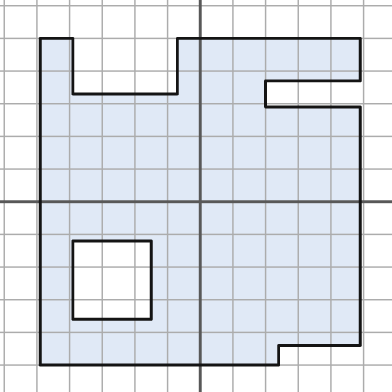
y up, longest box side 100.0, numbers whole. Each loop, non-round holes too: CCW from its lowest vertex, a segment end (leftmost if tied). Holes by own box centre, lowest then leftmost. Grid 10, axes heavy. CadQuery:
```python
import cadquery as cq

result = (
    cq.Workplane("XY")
    .moveTo(-49.0, -50.0)
    .lineTo(24.0, -50.0)
    .lineTo(24.0, -44.0)
    .lineTo(49.0, -44.0)
    .lineTo(49.0, 29.0)
    .lineTo(20.0, 29.0)
    .lineTo(20.0, 37.0)
    .lineTo(49.0, 37.0)
    .lineTo(49.0, 50.0)
    .lineTo(-7.0, 50.0)
    .lineTo(-7.0, 33.0)
    .lineTo(-39.0, 33.0)
    .lineTo(-39.0, 50.0)
    .lineTo(-49.0, 50.0)
    .close()
    .moveTo(-39.0, -36.0)
    .lineTo(-15.0, -36.0)
    .lineTo(-15.0, -12.0)
    .lineTo(-39.0, -12.0)
    .close()
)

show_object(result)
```